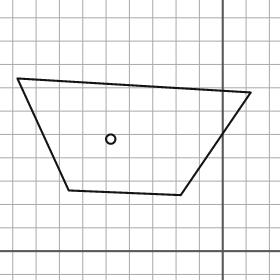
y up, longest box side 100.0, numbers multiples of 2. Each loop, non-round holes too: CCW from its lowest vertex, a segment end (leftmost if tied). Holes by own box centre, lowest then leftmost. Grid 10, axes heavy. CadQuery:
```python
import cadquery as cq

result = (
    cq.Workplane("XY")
    .moveTo(-18.0, 24.0)
    .lineTo(12.0, 68.0)
    .lineTo(-88.0, 74.0)
    .lineTo(-66.0, 26.0)
    .close()
    .moveTo(-48.0, 48.0)
    .circle(2.0)
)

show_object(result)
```